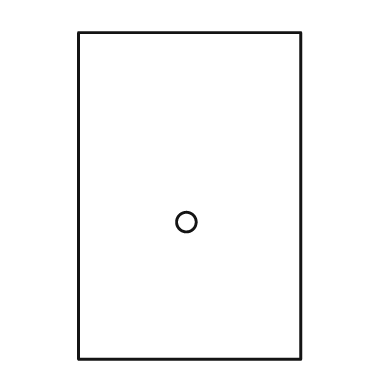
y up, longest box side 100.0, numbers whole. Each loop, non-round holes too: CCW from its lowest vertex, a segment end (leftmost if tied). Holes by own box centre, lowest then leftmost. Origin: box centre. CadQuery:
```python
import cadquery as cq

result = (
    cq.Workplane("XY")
    .moveTo(-34.0, -50.0)
    .lineTo(34.0, -50.0)
    .lineTo(34.0, 50.0)
    .lineTo(-34.0, 50.0)
    .close()
    .moveTo(-1.0, -8.0)
    .circle(3.0)
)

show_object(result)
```